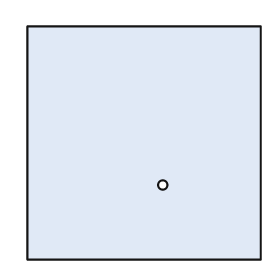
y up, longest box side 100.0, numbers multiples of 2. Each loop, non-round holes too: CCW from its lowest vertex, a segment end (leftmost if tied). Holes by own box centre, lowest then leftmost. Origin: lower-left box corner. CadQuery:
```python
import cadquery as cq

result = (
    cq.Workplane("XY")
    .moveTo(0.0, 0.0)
    .lineTo(100.0, 0.0)
    .lineTo(100.0, 100.0)
    .lineTo(0.0, 100.0)
    .close()
    .moveTo(58.0, 32.0)
    .circle(2.0)
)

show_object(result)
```